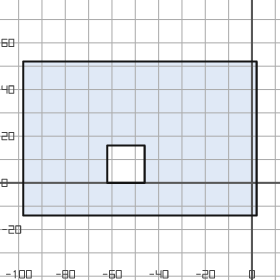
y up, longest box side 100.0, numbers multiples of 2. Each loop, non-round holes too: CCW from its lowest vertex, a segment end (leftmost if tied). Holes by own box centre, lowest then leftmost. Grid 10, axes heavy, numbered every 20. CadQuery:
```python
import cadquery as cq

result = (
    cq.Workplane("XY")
    .moveTo(-98.0, -14.0)
    .lineTo(2.0, -14.0)
    .lineTo(2.0, 52.0)
    .lineTo(-98.0, 52.0)
    .close()
    .moveTo(-62.0, 0.0)
    .lineTo(-46.0, 0.0)
    .lineTo(-46.0, 16.0)
    .lineTo(-62.0, 16.0)
    .close()
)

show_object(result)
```